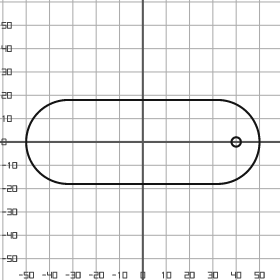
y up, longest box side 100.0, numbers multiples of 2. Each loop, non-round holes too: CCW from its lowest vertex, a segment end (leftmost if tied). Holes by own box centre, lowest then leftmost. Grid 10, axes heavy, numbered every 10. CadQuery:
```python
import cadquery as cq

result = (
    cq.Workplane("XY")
    .moveTo(-32.0, -18.0)
    .lineTo(32.0, -18.0)
    .threePointArc((50.0, 0.0), (32.0, 18.0))
    .lineTo(-32.0, 18.0)
    .threePointArc((-50.0, 0.0), (-32.0, -18.0))
    .close()
    .moveTo(40.0, 0.0)
    .circle(2.0)
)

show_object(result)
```